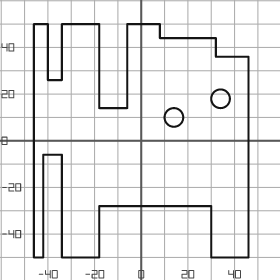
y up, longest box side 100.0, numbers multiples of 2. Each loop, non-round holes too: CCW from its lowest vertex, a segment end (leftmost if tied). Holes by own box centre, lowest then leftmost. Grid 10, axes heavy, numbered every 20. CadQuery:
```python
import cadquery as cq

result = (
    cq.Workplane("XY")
    .moveTo(-46.0, -50.0)
    .lineTo(-42.0, -50.0)
    .lineTo(-42.0, -6.0)
    .lineTo(-34.0, -6.0)
    .lineTo(-34.0, -50.0)
    .lineTo(-18.0, -50.0)
    .lineTo(-18.0, -28.0)
    .lineTo(30.0, -28.0)
    .lineTo(30.0, -50.0)
    .lineTo(46.0, -50.0)
    .lineTo(46.0, 36.0)
    .lineTo(32.0, 36.0)
    .lineTo(32.0, 44.0)
    .lineTo(8.0, 44.0)
    .lineTo(8.0, 50.0)
    .lineTo(-6.0, 50.0)
    .lineTo(-6.0, 14.0)
    .lineTo(-18.0, 14.0)
    .lineTo(-18.0, 50.0)
    .lineTo(-34.0, 50.0)
    .lineTo(-34.0, 26.0)
    .lineTo(-40.0, 26.0)
    .lineTo(-40.0, 50.0)
    .lineTo(-46.0, 50.0)
    .close()
    .moveTo(14.0, 10.0)
    .circle(4.0)
    .moveTo(34.0, 18.0)
    .circle(4.0)
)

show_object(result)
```